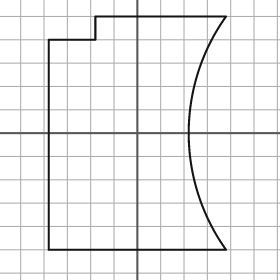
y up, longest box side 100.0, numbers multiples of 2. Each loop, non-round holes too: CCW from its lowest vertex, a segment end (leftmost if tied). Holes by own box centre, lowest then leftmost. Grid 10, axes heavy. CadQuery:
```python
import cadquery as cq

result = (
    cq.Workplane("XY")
    .moveTo(-38.0, -50.0)
    .lineTo(38.0, -50.0)
    .threePointArc((22.0, 0.0), (38.0, 50.0))
    .lineTo(-18.0, 50.0)
    .lineTo(-18.0, 40.0)
    .lineTo(-38.0, 40.0)
    .close()
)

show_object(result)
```